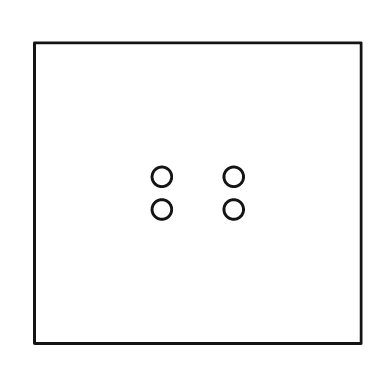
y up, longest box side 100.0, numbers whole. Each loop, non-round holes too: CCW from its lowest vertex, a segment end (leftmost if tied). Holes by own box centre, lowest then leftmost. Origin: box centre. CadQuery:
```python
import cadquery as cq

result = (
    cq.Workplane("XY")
    .moveTo(-50.0, -46.0)
    .lineTo(50.0, -46.0)
    .lineTo(50.0, 46.0)
    .lineTo(-50.0, 46.0)
    .close()
    .moveTo(-11.0, -5.0)
    .circle(3.0)
    .moveTo(11.0, -5.0)
    .circle(3.0)
    .moveTo(-11.0, 5.0)
    .circle(3.0)
    .moveTo(11.0, 5.0)
    .circle(3.0)
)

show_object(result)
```